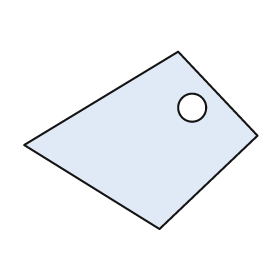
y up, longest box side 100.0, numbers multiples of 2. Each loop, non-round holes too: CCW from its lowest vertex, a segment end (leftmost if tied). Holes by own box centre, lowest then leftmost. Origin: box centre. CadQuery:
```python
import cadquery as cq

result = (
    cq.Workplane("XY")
    .moveTo(8.0, -38.0)
    .lineTo(50.0, 2.0)
    .lineTo(16.0, 38.0)
    .lineTo(-50.0, -2.0)
    .close()
    .moveTo(22.0, 14.0)
    .circle(6.0)
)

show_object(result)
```